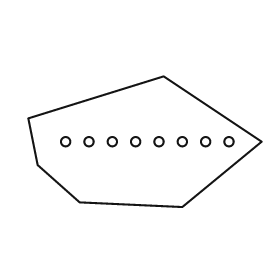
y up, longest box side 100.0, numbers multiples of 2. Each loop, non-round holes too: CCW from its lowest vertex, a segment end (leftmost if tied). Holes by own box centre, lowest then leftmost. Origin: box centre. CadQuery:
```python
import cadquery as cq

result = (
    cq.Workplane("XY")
    .moveTo(16.0, -28.0)
    .lineTo(50.0, 0.0)
    .lineTo(8.0, 28.0)
    .lineTo(-50.0, 10.0)
    .lineTo(-46.0, -10.0)
    .lineTo(-28.0, -26.0)
    .close()
    .moveTo(-34.0, 0.0)
    .circle(2.0)
    .moveTo(-24.0, 0.0)
    .circle(2.0)
    .moveTo(-14.0, 0.0)
    .circle(2.0)
    .moveTo(-4.0, 0.0)
    .circle(2.0)
    .moveTo(6.0, 0.0)
    .circle(2.0)
    .moveTo(16.0, 0.0)
    .circle(2.0)
    .moveTo(26.0, 0.0)
    .circle(2.0)
    .moveTo(36.0, 0.0)
    .circle(2.0)
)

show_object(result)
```